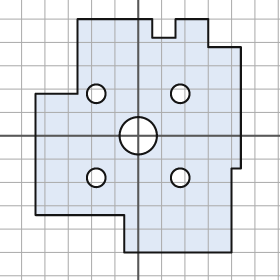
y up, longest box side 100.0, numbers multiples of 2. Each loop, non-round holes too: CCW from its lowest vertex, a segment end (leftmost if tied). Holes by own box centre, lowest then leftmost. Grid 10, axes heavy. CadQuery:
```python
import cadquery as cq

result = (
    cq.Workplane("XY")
    .moveTo(-6.0, -50.0)
    .lineTo(40.0, -50.0)
    .lineTo(40.0, -14.0)
    .lineTo(44.0, -14.0)
    .lineTo(44.0, 38.0)
    .lineTo(30.0, 38.0)
    .lineTo(30.0, 50.0)
    .lineTo(16.0, 50.0)
    .lineTo(16.0, 42.0)
    .lineTo(6.0, 42.0)
    .lineTo(6.0, 50.0)
    .lineTo(-26.0, 50.0)
    .lineTo(-26.0, 18.0)
    .lineTo(-44.0, 18.0)
    .lineTo(-44.0, -34.0)
    .lineTo(-6.0, -34.0)
    .close()
    .moveTo(-18.0, -18.0)
    .circle(4.0)
    .moveTo(18.0, -18.0)
    .circle(4.0)
    .moveTo(0.0, 0.0)
    .circle(8.0)
    .moveTo(-18.0, 18.0)
    .circle(4.0)
    .moveTo(18.0, 18.0)
    .circle(4.0)
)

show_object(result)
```